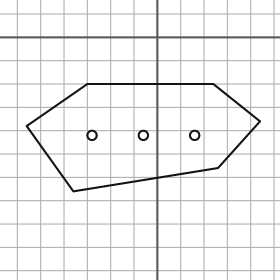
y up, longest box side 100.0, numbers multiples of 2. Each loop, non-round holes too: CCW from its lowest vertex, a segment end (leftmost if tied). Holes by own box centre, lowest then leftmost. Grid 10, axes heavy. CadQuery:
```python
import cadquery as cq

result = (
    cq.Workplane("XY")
    .moveTo(-36.0, -66.0)
    .lineTo(26.0, -56.0)
    .lineTo(44.0, -36.0)
    .lineTo(24.0, -20.0)
    .lineTo(-30.0, -20.0)
    .lineTo(-56.0, -38.0)
    .close()
    .moveTo(-28.0, -42.0)
    .circle(2.0)
    .moveTo(-6.0, -42.0)
    .circle(2.0)
    .moveTo(16.0, -42.0)
    .circle(2.0)
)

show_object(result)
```